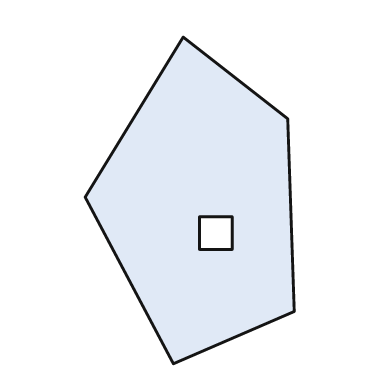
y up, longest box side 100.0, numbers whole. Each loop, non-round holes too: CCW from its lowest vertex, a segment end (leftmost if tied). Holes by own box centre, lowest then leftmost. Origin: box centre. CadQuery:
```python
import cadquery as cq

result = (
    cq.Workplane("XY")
    .moveTo(-5.0, -50.0)
    .lineTo(32.0, -34.0)
    .lineTo(30.0, 25.0)
    .lineTo(-2.0, 50.0)
    .lineTo(-32.0, 1.0)
    .close()
    .moveTo(3.0, -15.0)
    .lineTo(13.0, -15.0)
    .lineTo(13.0, -5.0)
    .lineTo(3.0, -5.0)
    .close()
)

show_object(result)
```